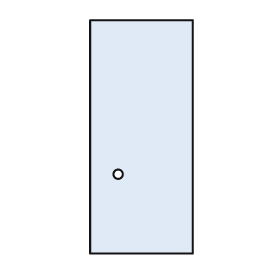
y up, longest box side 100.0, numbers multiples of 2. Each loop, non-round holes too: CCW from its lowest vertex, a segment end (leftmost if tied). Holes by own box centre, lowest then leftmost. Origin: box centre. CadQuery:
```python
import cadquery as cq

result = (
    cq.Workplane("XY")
    .moveTo(-22.0, -50.0)
    .lineTo(22.0, -50.0)
    .lineTo(22.0, 50.0)
    .lineTo(-22.0, 50.0)
    .close()
    .moveTo(-10.0, -16.0)
    .circle(2.0)
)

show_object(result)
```